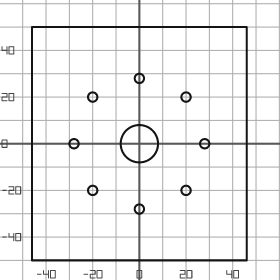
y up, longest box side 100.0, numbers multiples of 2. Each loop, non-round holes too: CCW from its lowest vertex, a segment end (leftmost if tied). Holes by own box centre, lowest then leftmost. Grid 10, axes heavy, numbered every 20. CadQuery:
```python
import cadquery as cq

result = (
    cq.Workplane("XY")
    .moveTo(-46.0, -50.0)
    .lineTo(46.0, -50.0)
    .lineTo(46.0, 50.0)
    .lineTo(-46.0, 50.0)
    .close()
    .moveTo(0.0, -28.0)
    .circle(2.0)
    .moveTo(-20.0, -20.0)
    .circle(2.0)
    .moveTo(20.0, -20.0)
    .circle(2.0)
    .moveTo(-28.0, 0.0)
    .circle(2.0)
    .moveTo(0.0, 0.0)
    .circle(8.0)
    .moveTo(28.0, 0.0)
    .circle(2.0)
    .moveTo(-20.0, 20.0)
    .circle(2.0)
    .moveTo(20.0, 20.0)
    .circle(2.0)
    .moveTo(0.0, 28.0)
    .circle(2.0)
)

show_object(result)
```